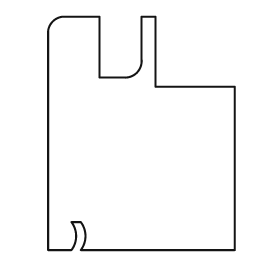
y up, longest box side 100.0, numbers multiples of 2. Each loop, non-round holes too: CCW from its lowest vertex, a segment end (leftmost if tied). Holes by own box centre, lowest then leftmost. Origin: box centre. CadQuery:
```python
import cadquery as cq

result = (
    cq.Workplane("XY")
    .moveTo(-40.0, -50.0)
    .lineTo(-30.0, -50.0)
    .threePointArc((-28.0, -44.0), (-30.0, -38.0))
    .lineTo(-26.0, -38.0)
    .threePointArc((-24.0, -44.0), (-26.0, -50.0))
    .lineTo(40.0, -50.0)
    .lineTo(40.0, 20.0)
    .lineTo(6.0, 20.0)
    .lineTo(6.0, 50.0)
    .lineTo(0.0, 50.0)
    .lineTo(0.0, 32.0)
    .threePointArc((-2.0, 26.0), (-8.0, 24.0))
    .lineTo(-18.0, 24.0)
    .lineTo(-18.0, 50.0)
    .lineTo(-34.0, 50.0)
    .threePointArc((-38.0, 48.0), (-40.0, 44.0))
    .close()
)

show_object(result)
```